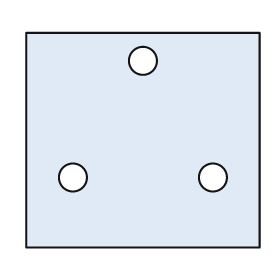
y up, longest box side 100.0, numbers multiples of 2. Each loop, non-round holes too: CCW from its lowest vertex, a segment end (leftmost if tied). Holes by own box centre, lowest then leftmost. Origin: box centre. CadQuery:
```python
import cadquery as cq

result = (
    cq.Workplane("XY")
    .moveTo(-50.0, -46.0)
    .lineTo(50.0, -46.0)
    .lineTo(50.0, 46.0)
    .lineTo(-50.0, 46.0)
    .close()
    .moveTo(-30.0, -16.0)
    .circle(6.0)
    .moveTo(30.0, -16.0)
    .circle(6.0)
    .moveTo(0.0, 34.0)
    .circle(6.0)
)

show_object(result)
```